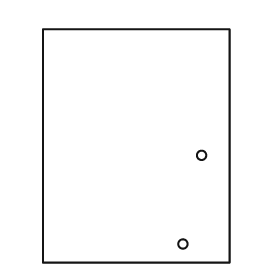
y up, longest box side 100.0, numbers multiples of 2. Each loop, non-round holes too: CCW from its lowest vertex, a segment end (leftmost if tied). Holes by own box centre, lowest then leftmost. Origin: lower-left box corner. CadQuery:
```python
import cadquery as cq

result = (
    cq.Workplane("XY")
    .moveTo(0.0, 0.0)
    .lineTo(80.0, 0.0)
    .lineTo(80.0, 100.0)
    .lineTo(0.0, 100.0)
    .close()
    .moveTo(60.0, 8.0)
    .circle(2.0)
    .moveTo(68.0, 46.0)
    .circle(2.0)
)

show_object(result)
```